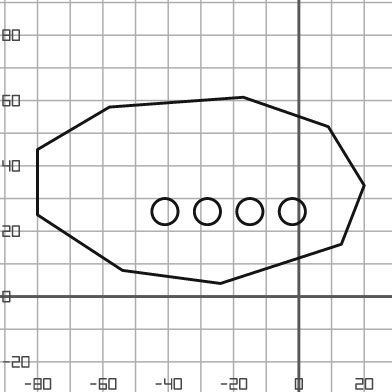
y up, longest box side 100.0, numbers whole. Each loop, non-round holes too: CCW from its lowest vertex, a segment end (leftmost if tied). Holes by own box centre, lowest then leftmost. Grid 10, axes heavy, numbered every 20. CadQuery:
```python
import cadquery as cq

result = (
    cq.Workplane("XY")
    .moveTo(-24.0, 4.0)
    .lineTo(13.0, 16.0)
    .lineTo(20.0, 34.0)
    .lineTo(9.0, 52.0)
    .lineTo(-17.0, 61.0)
    .lineTo(-58.0, 58.0)
    .lineTo(-80.0, 45.0)
    .lineTo(-80.0, 25.0)
    .lineTo(-54.0, 8.0)
    .close()
    .moveTo(-41.0, 26.0)
    .circle(4.0)
    .moveTo(-28.0, 26.0)
    .circle(4.0)
    .moveTo(-15.0, 26.0)
    .circle(4.0)
    .moveTo(-2.0, 26.0)
    .circle(4.0)
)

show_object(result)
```